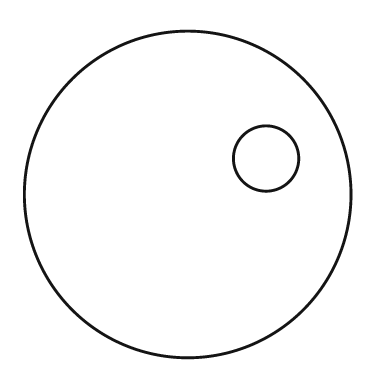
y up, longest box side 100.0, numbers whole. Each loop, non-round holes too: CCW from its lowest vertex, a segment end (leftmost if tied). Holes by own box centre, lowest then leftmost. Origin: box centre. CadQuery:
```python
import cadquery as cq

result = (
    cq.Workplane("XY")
    .moveTo(0.0, 0.0)
    .circle(50.0)
    .moveTo(24.0, 11.0)
    .circle(10.0)
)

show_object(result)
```